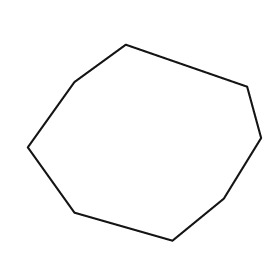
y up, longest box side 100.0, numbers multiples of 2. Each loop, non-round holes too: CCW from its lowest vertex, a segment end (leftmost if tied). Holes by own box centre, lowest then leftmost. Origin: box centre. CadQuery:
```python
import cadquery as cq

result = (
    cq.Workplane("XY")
    .moveTo(12.0, -42.0)
    .lineTo(34.0, -24.0)
    .lineTo(50.0, 2.0)
    .lineTo(44.0, 24.0)
    .lineTo(-8.0, 42.0)
    .lineTo(-30.0, 26.0)
    .lineTo(-50.0, -2.0)
    .lineTo(-30.0, -30.0)
    .close()
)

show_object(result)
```